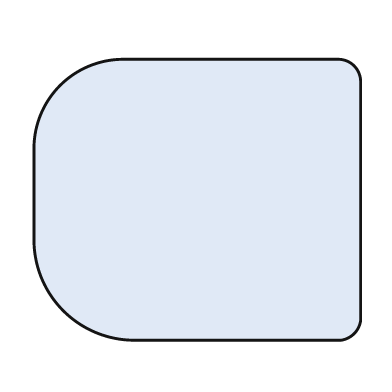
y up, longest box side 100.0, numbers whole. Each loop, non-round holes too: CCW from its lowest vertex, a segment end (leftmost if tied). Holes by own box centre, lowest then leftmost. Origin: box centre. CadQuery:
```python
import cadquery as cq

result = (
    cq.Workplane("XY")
    .moveTo(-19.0, -43.0)
    .lineTo(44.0, -43.0)
    .threePointArc((48.0, -41.0), (50.0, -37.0))
    .lineTo(50.0, 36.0)
    .threePointArc((48.0, 41.0), (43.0, 43.0))
    .lineTo(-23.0, 43.0)
    .threePointArc((-42.0, 35.0), (-50.0, 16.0))
    .lineTo(-50.0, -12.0)
    .threePointArc((-41.0, -34.0), (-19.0, -43.0))
    .close()
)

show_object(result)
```